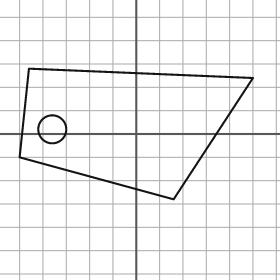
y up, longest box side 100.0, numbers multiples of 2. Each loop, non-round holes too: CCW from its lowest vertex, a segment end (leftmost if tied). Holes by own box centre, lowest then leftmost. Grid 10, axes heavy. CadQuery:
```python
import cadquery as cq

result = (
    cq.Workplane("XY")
    .moveTo(16.0, -28.0)
    .lineTo(50.0, 24.0)
    .lineTo(-46.0, 28.0)
    .lineTo(-50.0, -10.0)
    .close()
    .moveTo(-36.0, 2.0)
    .circle(6.0)
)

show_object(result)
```